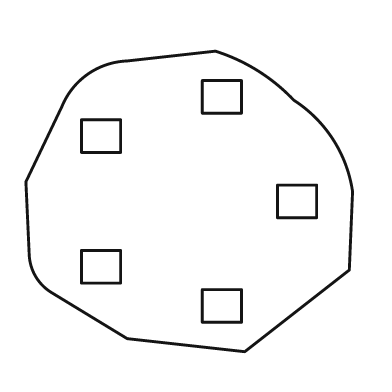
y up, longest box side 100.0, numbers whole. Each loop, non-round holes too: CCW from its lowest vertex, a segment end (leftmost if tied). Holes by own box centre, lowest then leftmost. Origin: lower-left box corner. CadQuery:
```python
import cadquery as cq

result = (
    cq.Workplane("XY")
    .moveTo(67.0, 0.0)
    .lineTo(99.0, 25.0)
    .lineTo(100.0, 49.0)
    .threePointArc((94.0, 65.0), (82.0, 77.0))
    .threePointArc((71.0, 86.0), (58.0, 92.0))
    .lineTo(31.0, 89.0)
    .threePointArc((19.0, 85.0), (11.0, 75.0))
    .lineTo(0.0, 52.0)
    .lineTo(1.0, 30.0)
    .threePointArc((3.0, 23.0), (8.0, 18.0))
    .lineTo(31.0, 4.0)
    .close()
    .moveTo(54.0, 9.0)
    .lineTo(66.0, 9.0)
    .lineTo(66.0, 19.0)
    .lineTo(54.0, 19.0)
    .close()
    .moveTo(17.0, 21.0)
    .lineTo(29.0, 21.0)
    .lineTo(29.0, 31.0)
    .lineTo(17.0, 31.0)
    .close()
    .moveTo(77.0, 41.0)
    .lineTo(89.0, 41.0)
    .lineTo(89.0, 51.0)
    .lineTo(77.0, 51.0)
    .close()
    .moveTo(17.0, 61.0)
    .lineTo(29.0, 61.0)
    .lineTo(29.0, 71.0)
    .lineTo(17.0, 71.0)
    .close()
    .moveTo(54.0, 73.0)
    .lineTo(66.0, 73.0)
    .lineTo(66.0, 83.0)
    .lineTo(54.0, 83.0)
    .close()
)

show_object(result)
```